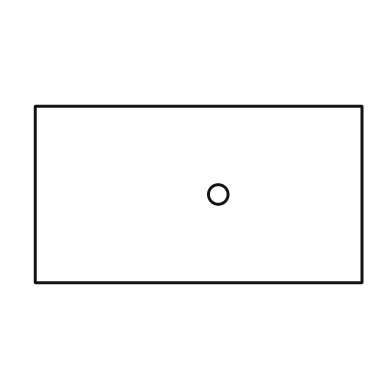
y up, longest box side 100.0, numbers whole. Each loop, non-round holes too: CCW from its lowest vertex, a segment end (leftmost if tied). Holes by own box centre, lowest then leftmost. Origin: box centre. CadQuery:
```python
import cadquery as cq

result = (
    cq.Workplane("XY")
    .moveTo(-50.0, -27.0)
    .lineTo(50.0, -27.0)
    .lineTo(50.0, 27.0)
    .lineTo(-50.0, 27.0)
    .close()
    .moveTo(6.0, 0.0)
    .circle(3.0)
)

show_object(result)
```